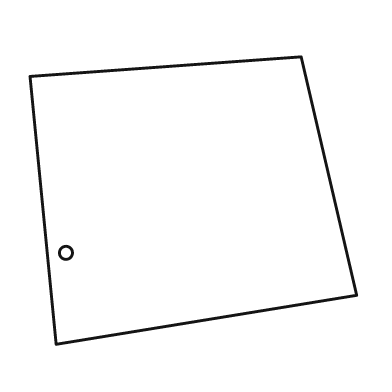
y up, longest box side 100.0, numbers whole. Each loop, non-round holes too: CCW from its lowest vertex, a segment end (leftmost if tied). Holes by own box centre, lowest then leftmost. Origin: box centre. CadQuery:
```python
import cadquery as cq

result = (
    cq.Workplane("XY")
    .moveTo(-42.0, -44.0)
    .lineTo(50.0, -29.0)
    .lineTo(33.0, 44.0)
    .lineTo(-50.0, 38.0)
    .close()
    .moveTo(-39.0, -16.0)
    .circle(2.0)
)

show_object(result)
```